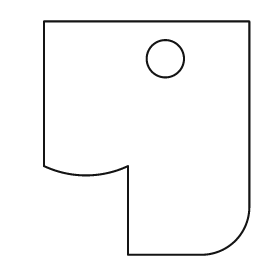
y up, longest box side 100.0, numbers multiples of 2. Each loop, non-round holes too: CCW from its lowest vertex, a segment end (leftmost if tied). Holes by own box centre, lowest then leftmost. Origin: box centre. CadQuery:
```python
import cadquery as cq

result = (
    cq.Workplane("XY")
    .moveTo(-8.0, -50.0)
    .lineTo(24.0, -50.0)
    .threePointArc((38.0, -44.0), (44.0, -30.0))
    .lineTo(44.0, 50.0)
    .lineTo(-44.0, 50.0)
    .lineTo(-44.0, -12.0)
    .threePointArc((-26.0, -16.0), (-8.0, -12.0))
    .close()
    .moveTo(8.0, 34.0)
    .circle(8.0)
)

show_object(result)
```